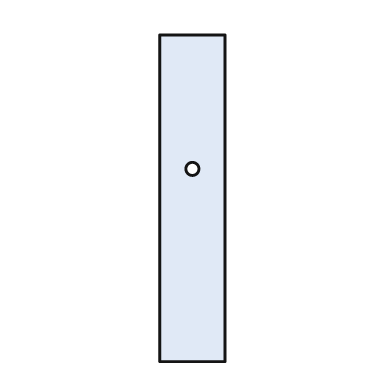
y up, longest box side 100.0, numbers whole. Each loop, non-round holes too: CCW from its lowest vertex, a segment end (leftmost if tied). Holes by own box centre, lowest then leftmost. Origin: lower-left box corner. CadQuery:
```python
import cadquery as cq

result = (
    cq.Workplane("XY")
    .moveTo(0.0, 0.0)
    .lineTo(20.0, 0.0)
    .lineTo(20.0, 100.0)
    .lineTo(0.0, 100.0)
    .close()
    .moveTo(10.0, 59.0)
    .circle(2.0)
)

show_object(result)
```